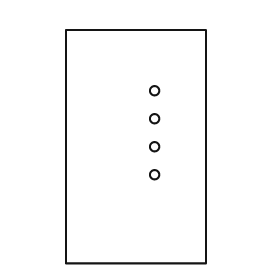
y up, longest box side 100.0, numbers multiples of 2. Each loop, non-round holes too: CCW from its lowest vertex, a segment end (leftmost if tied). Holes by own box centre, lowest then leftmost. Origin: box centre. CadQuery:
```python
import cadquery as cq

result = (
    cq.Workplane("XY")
    .moveTo(-30.0, -50.0)
    .lineTo(30.0, -50.0)
    .lineTo(30.0, 50.0)
    .lineTo(-30.0, 50.0)
    .close()
    .moveTo(8.0, -12.0)
    .circle(2.0)
    .moveTo(8.0, 0.0)
    .circle(2.0)
    .moveTo(8.0, 12.0)
    .circle(2.0)
    .moveTo(8.0, 24.0)
    .circle(2.0)
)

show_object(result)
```